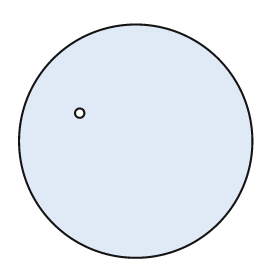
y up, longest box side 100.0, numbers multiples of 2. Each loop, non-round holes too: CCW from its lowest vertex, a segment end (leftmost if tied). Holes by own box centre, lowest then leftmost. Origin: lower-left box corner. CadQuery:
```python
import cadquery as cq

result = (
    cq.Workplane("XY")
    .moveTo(50.0, 50.0)
    .circle(50.0)
    .moveTo(26.0, 62.0)
    .circle(2.0)
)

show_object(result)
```